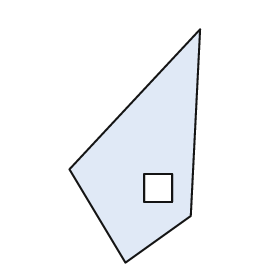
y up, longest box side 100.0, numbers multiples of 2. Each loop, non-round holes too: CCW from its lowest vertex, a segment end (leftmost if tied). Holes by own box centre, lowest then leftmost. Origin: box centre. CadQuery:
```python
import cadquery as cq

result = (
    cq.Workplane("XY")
    .moveTo(-4.0, -50.0)
    .lineTo(24.0, -30.0)
    .lineTo(28.0, 50.0)
    .lineTo(-28.0, -10.0)
    .close()
    .moveTo(4.0, -24.0)
    .lineTo(16.0, -24.0)
    .lineTo(16.0, -12.0)
    .lineTo(4.0, -12.0)
    .close()
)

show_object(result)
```